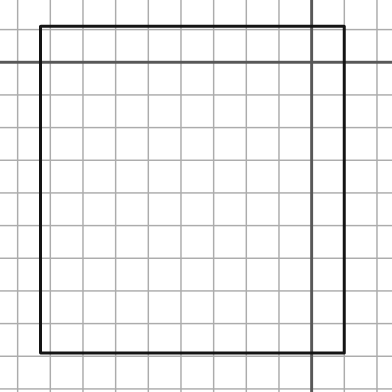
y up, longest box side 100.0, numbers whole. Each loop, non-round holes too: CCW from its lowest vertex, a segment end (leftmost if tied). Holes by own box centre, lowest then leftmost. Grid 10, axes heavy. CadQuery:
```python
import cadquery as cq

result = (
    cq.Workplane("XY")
    .moveTo(-83.0, -89.0)
    .lineTo(10.0, -89.0)
    .lineTo(10.0, 11.0)
    .lineTo(-83.0, 11.0)
    .close()
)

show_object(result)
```